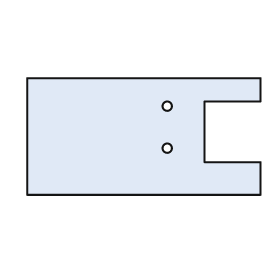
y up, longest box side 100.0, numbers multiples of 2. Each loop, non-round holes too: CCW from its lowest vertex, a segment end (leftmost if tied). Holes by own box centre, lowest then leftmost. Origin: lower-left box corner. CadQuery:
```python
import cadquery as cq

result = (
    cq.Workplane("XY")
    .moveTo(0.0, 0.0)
    .lineTo(100.0, 0.0)
    .lineTo(100.0, 14.0)
    .lineTo(76.0, 14.0)
    .lineTo(76.0, 40.0)
    .lineTo(100.0, 40.0)
    .lineTo(100.0, 50.0)
    .lineTo(0.0, 50.0)
    .close()
    .moveTo(60.0, 20.0)
    .circle(2.0)
    .moveTo(60.0, 38.0)
    .circle(2.0)
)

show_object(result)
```